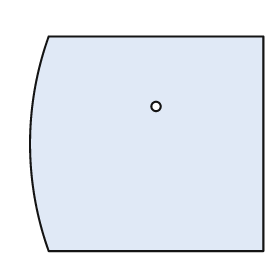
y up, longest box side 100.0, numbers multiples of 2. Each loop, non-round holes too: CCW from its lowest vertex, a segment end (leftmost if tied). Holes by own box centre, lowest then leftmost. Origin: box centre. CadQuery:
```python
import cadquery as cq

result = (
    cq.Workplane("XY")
    .moveTo(-42.0, -46.0)
    .lineTo(50.0, -46.0)
    .lineTo(50.0, 46.0)
    .lineTo(-42.0, 46.0)
    .threePointArc((-50.0, 0.0), (-42.0, -46.0))
    .close()
    .moveTo(4.0, 16.0)
    .circle(2.0)
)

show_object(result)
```